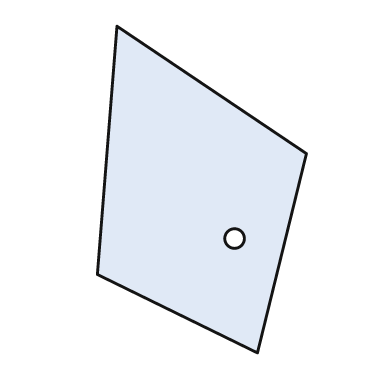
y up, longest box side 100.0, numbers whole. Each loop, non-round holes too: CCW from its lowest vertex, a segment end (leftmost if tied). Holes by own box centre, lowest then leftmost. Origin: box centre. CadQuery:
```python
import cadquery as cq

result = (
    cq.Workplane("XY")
    .moveTo(17.0, -50.0)
    .lineTo(32.0, 11.0)
    .lineTo(-26.0, 50.0)
    .lineTo(-32.0, -26.0)
    .close()
    .moveTo(10.0, -15.0)
    .circle(3.0)
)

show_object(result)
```